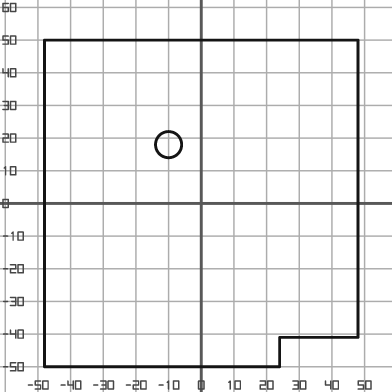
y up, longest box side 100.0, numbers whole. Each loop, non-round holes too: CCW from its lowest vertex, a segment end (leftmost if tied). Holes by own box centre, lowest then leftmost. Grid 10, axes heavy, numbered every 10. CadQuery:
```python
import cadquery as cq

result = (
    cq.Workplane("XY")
    .moveTo(-48.0, -50.0)
    .lineTo(24.0, -50.0)
    .lineTo(24.0, -41.0)
    .lineTo(48.0, -41.0)
    .lineTo(48.0, 50.0)
    .lineTo(-48.0, 50.0)
    .close()
    .moveTo(-10.0, 18.0)
    .circle(4.0)
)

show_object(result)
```